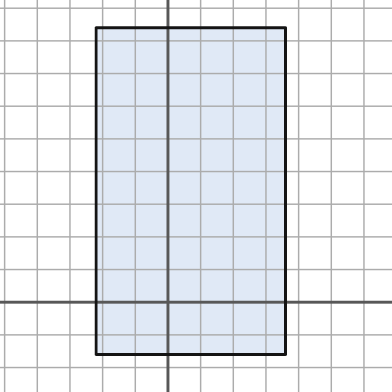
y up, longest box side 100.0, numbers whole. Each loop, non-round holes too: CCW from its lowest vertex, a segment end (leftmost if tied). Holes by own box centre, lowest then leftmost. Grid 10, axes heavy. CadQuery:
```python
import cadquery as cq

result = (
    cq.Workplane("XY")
    .moveTo(-22.0, -16.0)
    .lineTo(36.0, -16.0)
    .lineTo(36.0, 84.0)
    .lineTo(-22.0, 84.0)
    .close()
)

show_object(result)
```